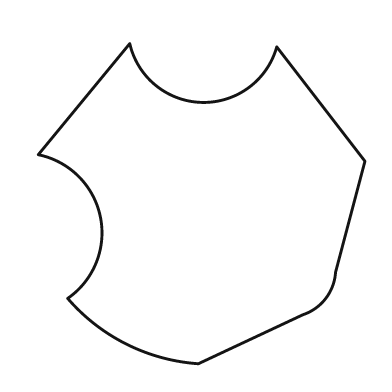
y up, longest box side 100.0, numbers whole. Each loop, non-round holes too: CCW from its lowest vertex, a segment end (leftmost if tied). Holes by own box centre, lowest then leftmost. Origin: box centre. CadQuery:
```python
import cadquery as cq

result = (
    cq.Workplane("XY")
    .moveTo(-1.0, -49.0)
    .lineTo(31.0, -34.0)
    .threePointArc((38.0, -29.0), (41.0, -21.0))
    .lineTo(50.0, 13.0)
    .lineTo(23.0, 48.0)
    .threePointArc((0.0, 31.0), (-22.0, 49.0))
    .lineTo(-50.0, 15.0)
    .threePointArc((-31.0, -4.0), (-41.0, -29.0))
    .threePointArc((-23.0, -43.0), (-1.0, -49.0))
    .close()
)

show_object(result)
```